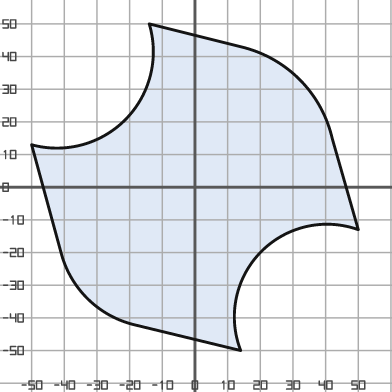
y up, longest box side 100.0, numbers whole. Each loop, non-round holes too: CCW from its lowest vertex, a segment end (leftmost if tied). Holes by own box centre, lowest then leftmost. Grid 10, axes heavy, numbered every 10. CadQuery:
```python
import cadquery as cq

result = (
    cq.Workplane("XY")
    .moveTo(14.0, -50.0)
    .threePointArc((20.0, -20.0), (50.0, -13.0))
    .lineTo(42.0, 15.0)
    .threePointArc((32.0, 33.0), (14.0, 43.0))
    .lineTo(-14.0, 50.0)
    .threePointArc((-21.0, 21.0), (-50.0, 13.0))
    .lineTo(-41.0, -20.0)
    .threePointArc((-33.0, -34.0), (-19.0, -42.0))
    .close()
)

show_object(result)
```